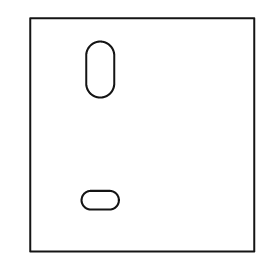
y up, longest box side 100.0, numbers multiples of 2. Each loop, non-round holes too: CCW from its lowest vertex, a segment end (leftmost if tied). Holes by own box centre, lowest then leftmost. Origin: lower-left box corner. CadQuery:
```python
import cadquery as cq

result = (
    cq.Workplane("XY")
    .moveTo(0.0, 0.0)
    .lineTo(96.0, 0.0)
    .lineTo(96.0, 100.0)
    .lineTo(0.0, 100.0)
    .close()
    .moveTo(26.0, 18.0)
    .lineTo(34.0, 18.0)
    .threePointArc((38.0, 22.0), (34.0, 26.0))
    .lineTo(26.0, 26.0)
    .threePointArc((22.0, 22.0), (26.0, 18.0))
    .close()
    .moveTo(24.0, 72.0)
    .threePointArc((30.0, 66.0), (36.0, 72.0))
    .lineTo(36.0, 84.0)
    .threePointArc((30.0, 90.0), (24.0, 84.0))
    .close()
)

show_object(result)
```